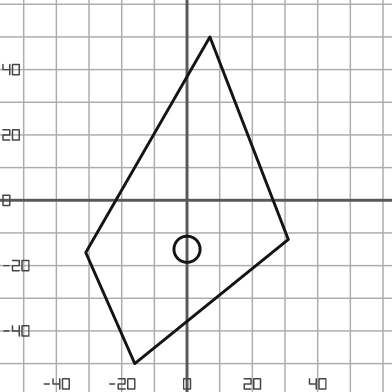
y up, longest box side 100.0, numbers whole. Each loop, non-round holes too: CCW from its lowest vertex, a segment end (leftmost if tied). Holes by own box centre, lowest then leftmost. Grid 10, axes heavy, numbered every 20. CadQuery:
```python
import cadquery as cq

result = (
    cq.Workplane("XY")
    .moveTo(-16.0, -50.0)
    .lineTo(31.0, -12.0)
    .lineTo(7.0, 50.0)
    .lineTo(-31.0, -16.0)
    .close()
    .moveTo(0.0, -15.0)
    .circle(4.0)
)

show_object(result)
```